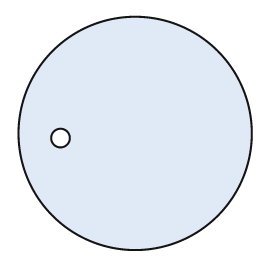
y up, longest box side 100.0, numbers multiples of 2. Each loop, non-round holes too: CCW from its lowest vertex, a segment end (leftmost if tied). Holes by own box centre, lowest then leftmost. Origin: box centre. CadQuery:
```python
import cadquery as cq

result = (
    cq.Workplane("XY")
    .moveTo(0.0, 0.0)
    .circle(50.0)
    .moveTo(-32.0, -2.0)
    .circle(4.0)
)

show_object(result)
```